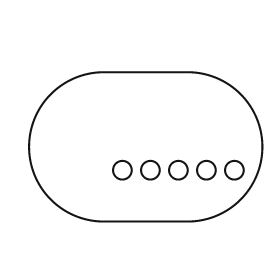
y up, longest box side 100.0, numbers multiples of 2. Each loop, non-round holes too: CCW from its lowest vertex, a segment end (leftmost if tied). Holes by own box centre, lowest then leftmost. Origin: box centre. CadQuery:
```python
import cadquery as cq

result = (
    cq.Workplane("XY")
    .moveTo(-18.0, -32.0)
    .lineTo(18.0, -32.0)
    .threePointArc((50.0, 0.0), (18.0, 32.0))
    .lineTo(-18.0, 32.0)
    .threePointArc((-50.0, 0.0), (-18.0, -32.0))
    .close()
    .moveTo(-10.0, -10.0)
    .circle(4.0)
    .moveTo(2.0, -10.0)
    .circle(4.0)
    .moveTo(14.0, -10.0)
    .circle(4.0)
    .moveTo(26.0, -10.0)
    .circle(4.0)
    .moveTo(38.0, -10.0)
    .circle(4.0)
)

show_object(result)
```